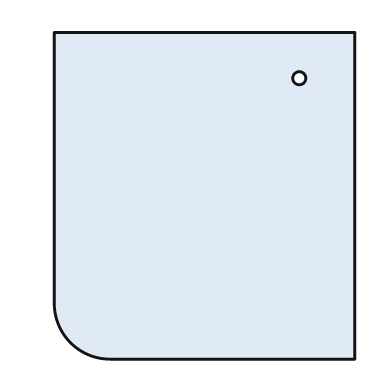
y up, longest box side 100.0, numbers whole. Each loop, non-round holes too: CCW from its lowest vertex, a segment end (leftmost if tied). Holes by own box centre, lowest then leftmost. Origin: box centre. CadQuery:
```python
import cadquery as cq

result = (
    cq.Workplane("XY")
    .moveTo(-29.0, -50.0)
    .lineTo(46.0, -50.0)
    .lineTo(46.0, 50.0)
    .lineTo(-46.0, 50.0)
    .lineTo(-46.0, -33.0)
    .threePointArc((-41.0, -45.0), (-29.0, -50.0))
    .close()
    .moveTo(29.0, 36.0)
    .circle(2.0)
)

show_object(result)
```